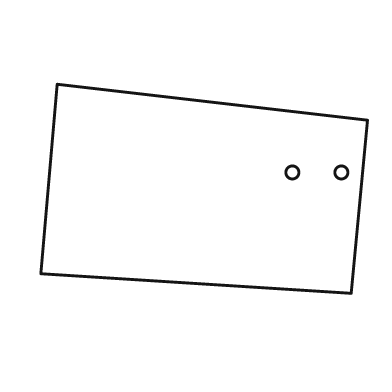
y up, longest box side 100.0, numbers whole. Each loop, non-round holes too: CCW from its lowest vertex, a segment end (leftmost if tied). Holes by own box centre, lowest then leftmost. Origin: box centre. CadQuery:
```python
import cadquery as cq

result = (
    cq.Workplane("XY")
    .moveTo(45.0, -32.0)
    .lineTo(50.0, 21.0)
    .lineTo(-45.0, 32.0)
    .lineTo(-50.0, -26.0)
    .close()
    .moveTo(27.0, 5.0)
    .circle(2.0)
    .moveTo(42.0, 5.0)
    .circle(2.0)
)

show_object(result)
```